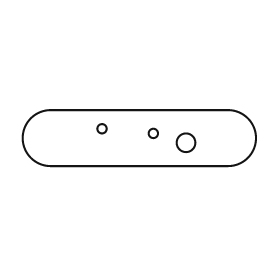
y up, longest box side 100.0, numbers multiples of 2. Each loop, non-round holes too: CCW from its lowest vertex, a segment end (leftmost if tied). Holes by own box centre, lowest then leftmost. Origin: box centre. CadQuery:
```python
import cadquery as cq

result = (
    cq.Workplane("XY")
    .moveTo(-38.0, -12.0)
    .lineTo(38.0, -12.0)
    .threePointArc((50.0, 0.0), (38.0, 12.0))
    .lineTo(-38.0, 12.0)
    .threePointArc((-50.0, 0.0), (-38.0, -12.0))
    .close()
    .moveTo(20.0, -2.0)
    .circle(4.0)
    .moveTo(6.0, 2.0)
    .circle(2.0)
    .moveTo(-16.0, 4.0)
    .circle(2.0)
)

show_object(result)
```